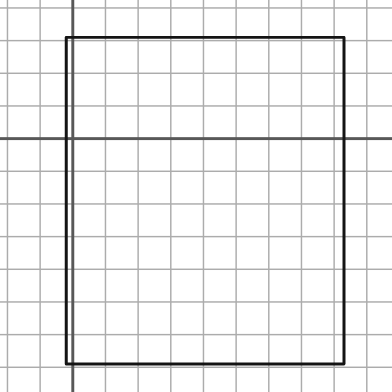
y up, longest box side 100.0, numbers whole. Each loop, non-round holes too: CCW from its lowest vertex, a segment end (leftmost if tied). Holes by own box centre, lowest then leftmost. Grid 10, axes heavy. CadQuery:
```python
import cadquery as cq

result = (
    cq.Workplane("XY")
    .moveTo(-2.0, -69.0)
    .lineTo(83.0, -69.0)
    .lineTo(83.0, 31.0)
    .lineTo(-2.0, 31.0)
    .close()
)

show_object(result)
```